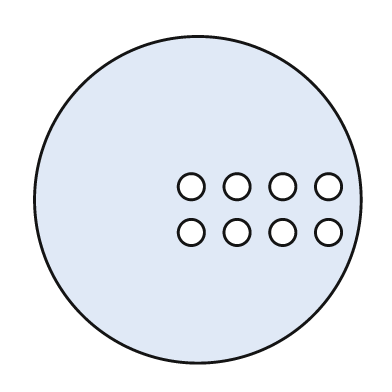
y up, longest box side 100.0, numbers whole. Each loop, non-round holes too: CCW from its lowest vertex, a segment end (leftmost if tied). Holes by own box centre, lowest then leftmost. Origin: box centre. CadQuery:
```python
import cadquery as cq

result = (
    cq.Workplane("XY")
    .moveTo(0.0, 0.0)
    .circle(50.0)
    .moveTo(-2.0, -10.0)
    .circle(4.0)
    .moveTo(12.0, -10.0)
    .circle(4.0)
    .moveTo(26.0, -10.0)
    .circle(4.0)
    .moveTo(40.0, -10.0)
    .circle(4.0)
    .moveTo(-2.0, 4.0)
    .circle(4.0)
    .moveTo(12.0, 4.0)
    .circle(4.0)
    .moveTo(26.0, 4.0)
    .circle(4.0)
    .moveTo(40.0, 4.0)
    .circle(4.0)
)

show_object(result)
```